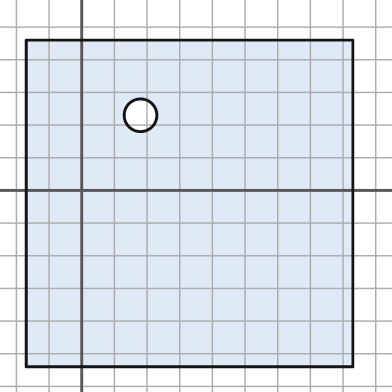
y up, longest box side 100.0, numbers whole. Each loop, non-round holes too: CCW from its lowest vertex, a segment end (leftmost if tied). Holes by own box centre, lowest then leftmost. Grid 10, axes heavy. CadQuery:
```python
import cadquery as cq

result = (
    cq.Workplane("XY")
    .moveTo(-17.0, -54.0)
    .lineTo(83.0, -54.0)
    .lineTo(83.0, 46.0)
    .lineTo(-17.0, 46.0)
    .close()
    .moveTo(18.0, 23.0)
    .circle(5.0)
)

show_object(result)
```